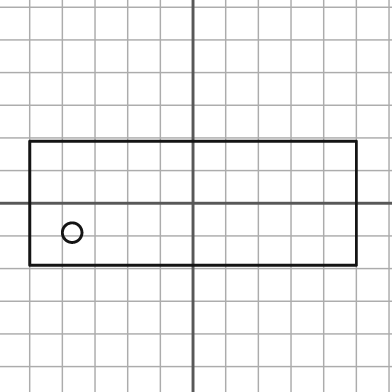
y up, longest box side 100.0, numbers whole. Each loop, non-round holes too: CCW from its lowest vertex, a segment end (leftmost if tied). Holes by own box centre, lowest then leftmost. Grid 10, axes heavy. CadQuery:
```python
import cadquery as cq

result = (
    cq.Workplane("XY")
    .moveTo(-50.0, -19.0)
    .lineTo(50.0, -19.0)
    .lineTo(50.0, 19.0)
    .lineTo(-50.0, 19.0)
    .close()
    .moveTo(-37.0, -9.0)
    .circle(3.0)
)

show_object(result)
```